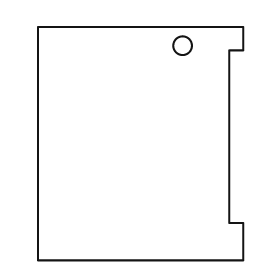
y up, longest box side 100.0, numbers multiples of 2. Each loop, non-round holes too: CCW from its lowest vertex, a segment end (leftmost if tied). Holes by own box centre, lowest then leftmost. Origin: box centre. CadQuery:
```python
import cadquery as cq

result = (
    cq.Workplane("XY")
    .moveTo(-44.0, -50.0)
    .lineTo(44.0, -50.0)
    .lineTo(44.0, -34.0)
    .lineTo(38.0, -34.0)
    .lineTo(38.0, 40.0)
    .lineTo(44.0, 40.0)
    .lineTo(44.0, 50.0)
    .lineTo(-44.0, 50.0)
    .close()
    .moveTo(18.0, 42.0)
    .circle(4.0)
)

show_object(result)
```